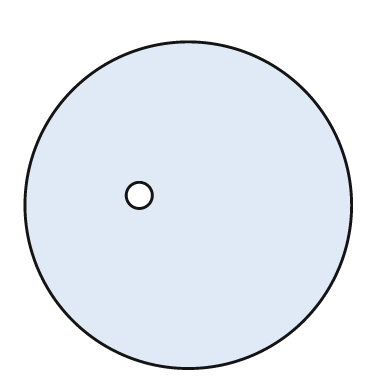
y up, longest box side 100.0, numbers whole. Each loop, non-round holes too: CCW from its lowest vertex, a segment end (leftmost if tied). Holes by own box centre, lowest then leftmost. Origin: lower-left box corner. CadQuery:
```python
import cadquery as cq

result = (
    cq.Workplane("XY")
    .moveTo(50.0, 50.0)
    .circle(50.0)
    .moveTo(35.0, 53.0)
    .circle(4.0)
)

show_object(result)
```